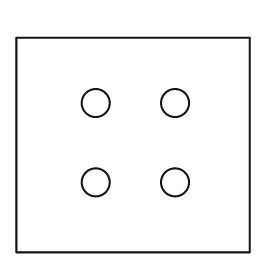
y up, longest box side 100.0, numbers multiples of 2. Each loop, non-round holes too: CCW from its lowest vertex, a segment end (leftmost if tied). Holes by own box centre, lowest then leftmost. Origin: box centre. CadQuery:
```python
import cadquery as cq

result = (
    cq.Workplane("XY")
    .moveTo(-50.0, -46.0)
    .lineTo(50.0, -46.0)
    .lineTo(50.0, 46.0)
    .lineTo(-50.0, 46.0)
    .close()
    .moveTo(-16.0, -16.0)
    .circle(6.0)
    .moveTo(18.0, -16.0)
    .circle(6.0)
    .moveTo(-16.0, 18.0)
    .circle(6.0)
    .moveTo(18.0, 18.0)
    .circle(6.0)
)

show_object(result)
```